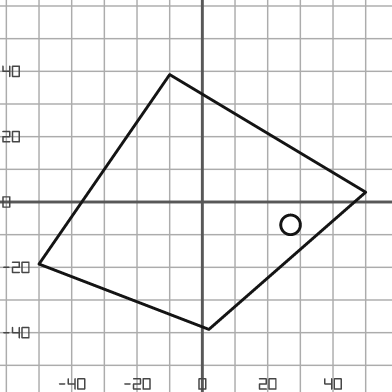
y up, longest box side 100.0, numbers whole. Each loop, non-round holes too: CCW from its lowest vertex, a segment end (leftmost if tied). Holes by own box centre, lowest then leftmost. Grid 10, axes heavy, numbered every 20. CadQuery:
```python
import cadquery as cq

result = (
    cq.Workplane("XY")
    .moveTo(2.0, -39.0)
    .lineTo(50.0, 3.0)
    .lineTo(-10.0, 39.0)
    .lineTo(-50.0, -19.0)
    .close()
    .moveTo(27.0, -7.0)
    .circle(3.0)
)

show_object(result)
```